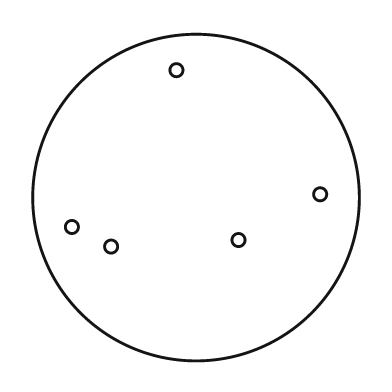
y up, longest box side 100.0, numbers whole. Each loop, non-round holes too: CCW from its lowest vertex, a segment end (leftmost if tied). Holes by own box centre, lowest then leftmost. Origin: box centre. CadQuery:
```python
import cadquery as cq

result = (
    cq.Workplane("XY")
    .moveTo(0.0, 0.0)
    .circle(50.0)
    .moveTo(-26.0, -15.0)
    .circle(2.0)
    .moveTo(13.0, -13.0)
    .circle(2.0)
    .moveTo(-38.0, -9.0)
    .circle(2.0)
    .moveTo(38.0, 1.0)
    .circle(2.0)
    .moveTo(-6.0, 39.0)
    .circle(2.0)
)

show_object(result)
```